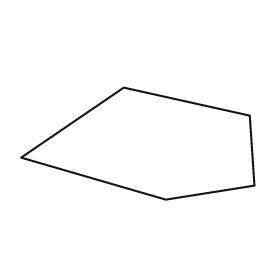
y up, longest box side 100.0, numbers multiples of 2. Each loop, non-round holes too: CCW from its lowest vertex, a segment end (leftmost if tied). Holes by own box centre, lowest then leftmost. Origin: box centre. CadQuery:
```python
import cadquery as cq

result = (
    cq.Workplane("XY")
    .moveTo(12.0, -24.0)
    .lineTo(50.0, -18.0)
    .lineTo(48.0, 12.0)
    .lineTo(-6.0, 24.0)
    .lineTo(-50.0, -6.0)
    .close()
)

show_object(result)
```